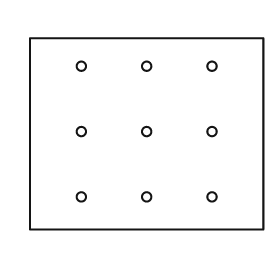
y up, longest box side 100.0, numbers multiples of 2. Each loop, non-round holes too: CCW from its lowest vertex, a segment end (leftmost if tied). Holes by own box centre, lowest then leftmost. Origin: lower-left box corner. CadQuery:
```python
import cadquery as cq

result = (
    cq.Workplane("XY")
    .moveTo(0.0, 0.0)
    .lineTo(100.0, 0.0)
    .lineTo(100.0, 82.0)
    .lineTo(0.0, 82.0)
    .close()
    .moveTo(22.0, 14.0)
    .circle(2.0)
    .moveTo(50.0, 14.0)
    .circle(2.0)
    .moveTo(78.0, 14.0)
    .circle(2.0)
    .moveTo(22.0, 42.0)
    .circle(2.0)
    .moveTo(50.0, 42.0)
    .circle(2.0)
    .moveTo(78.0, 42.0)
    .circle(2.0)
    .moveTo(22.0, 70.0)
    .circle(2.0)
    .moveTo(50.0, 70.0)
    .circle(2.0)
    .moveTo(78.0, 70.0)
    .circle(2.0)
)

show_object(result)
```